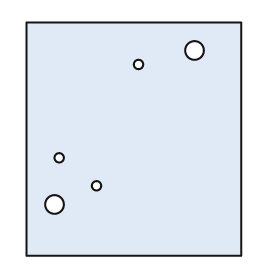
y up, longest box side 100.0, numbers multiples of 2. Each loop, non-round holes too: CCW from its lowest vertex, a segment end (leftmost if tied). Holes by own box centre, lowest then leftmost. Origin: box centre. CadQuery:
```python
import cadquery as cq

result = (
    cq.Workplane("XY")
    .moveTo(-46.0, -50.0)
    .lineTo(46.0, -50.0)
    .lineTo(46.0, 50.0)
    .lineTo(-46.0, 50.0)
    .close()
    .moveTo(-34.0, -28.0)
    .circle(4.0)
    .moveTo(-16.0, -20.0)
    .circle(2.0)
    .moveTo(-32.0, -8.0)
    .circle(2.0)
    .moveTo(2.0, 32.0)
    .circle(2.0)
    .moveTo(26.0, 38.0)
    .circle(4.0)
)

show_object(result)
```